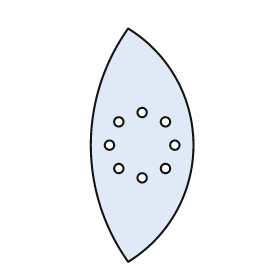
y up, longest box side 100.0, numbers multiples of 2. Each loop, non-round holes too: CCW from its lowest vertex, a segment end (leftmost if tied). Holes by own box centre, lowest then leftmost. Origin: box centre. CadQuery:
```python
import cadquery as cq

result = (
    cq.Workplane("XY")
    .moveTo(-6.0, -50.0)
    .threePointArc((22.0, 0.0), (-6.0, 50.0))
    .threePointArc((-22.0, 0.0), (-6.0, -50.0))
    .close()
    .moveTo(0.0, -14.0)
    .circle(2.0)
    .moveTo(-10.0, -10.0)
    .circle(2.0)
    .moveTo(10.0, -10.0)
    .circle(2.0)
    .moveTo(-14.0, 0.0)
    .circle(2.0)
    .moveTo(14.0, 0.0)
    .circle(2.0)
    .moveTo(-10.0, 10.0)
    .circle(2.0)
    .moveTo(10.0, 10.0)
    .circle(2.0)
    .moveTo(0.0, 14.0)
    .circle(2.0)
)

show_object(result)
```